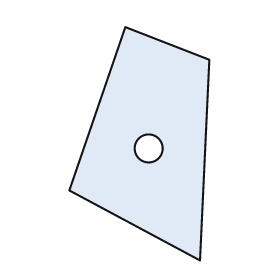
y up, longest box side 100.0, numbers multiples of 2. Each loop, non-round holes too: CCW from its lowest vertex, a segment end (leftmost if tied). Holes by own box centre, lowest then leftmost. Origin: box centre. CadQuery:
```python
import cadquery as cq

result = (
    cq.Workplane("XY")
    .moveTo(26.0, -50.0)
    .lineTo(30.0, 36.0)
    .lineTo(-6.0, 50.0)
    .lineTo(-30.0, -20.0)
    .close()
    .moveTo(4.0, -2.0)
    .circle(6.0)
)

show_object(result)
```